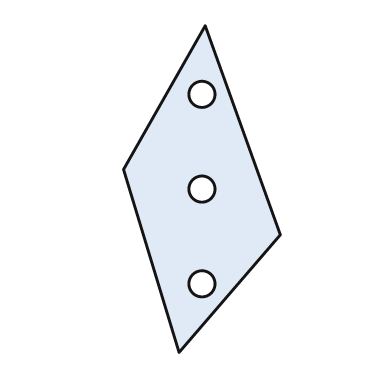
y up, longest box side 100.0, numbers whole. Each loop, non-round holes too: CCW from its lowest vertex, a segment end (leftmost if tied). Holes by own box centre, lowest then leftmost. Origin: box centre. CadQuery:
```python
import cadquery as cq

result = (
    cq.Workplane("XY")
    .moveTo(-7.0, -50.0)
    .lineTo(24.0, -14.0)
    .lineTo(1.0, 50.0)
    .lineTo(-24.0, 6.0)
    .close()
    .moveTo(0.0, -29.0)
    .circle(4.0)
    .moveTo(0.0, 0.0)
    .circle(4.0)
    .moveTo(0.0, 29.0)
    .circle(4.0)
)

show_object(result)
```